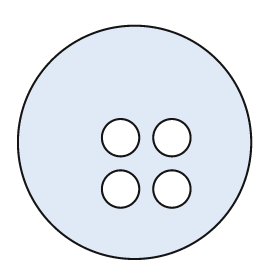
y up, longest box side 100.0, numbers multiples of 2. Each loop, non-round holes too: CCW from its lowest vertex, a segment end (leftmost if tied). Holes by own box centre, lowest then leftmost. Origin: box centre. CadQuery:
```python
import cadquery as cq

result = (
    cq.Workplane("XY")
    .moveTo(0.0, 0.0)
    .circle(50.0)
    .moveTo(-6.0, -20.0)
    .circle(8.0)
    .moveTo(16.0, -20.0)
    .circle(8.0)
    .moveTo(-6.0, 2.0)
    .circle(8.0)
    .moveTo(16.0, 2.0)
    .circle(8.0)
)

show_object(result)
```